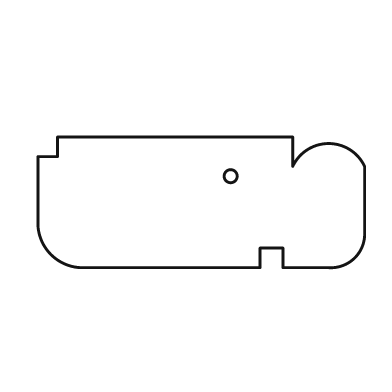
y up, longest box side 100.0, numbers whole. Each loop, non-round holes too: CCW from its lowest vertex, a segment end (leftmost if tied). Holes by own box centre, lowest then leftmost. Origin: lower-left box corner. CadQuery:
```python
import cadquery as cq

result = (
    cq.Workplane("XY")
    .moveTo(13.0, 0.0)
    .lineTo(68.0, 0.0)
    .lineTo(68.0, 6.0)
    .lineTo(75.0, 6.0)
    .lineTo(75.0, 0.0)
    .lineTo(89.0, 0.0)
    .threePointArc((97.0, 3.0), (100.0, 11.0))
    .lineTo(100.0, 31.0)
    .threePointArc((89.0, 38.0), (78.0, 31.0))
    .lineTo(78.0, 40.0)
    .lineTo(6.0, 40.0)
    .lineTo(6.0, 34.0)
    .lineTo(0.0, 34.0)
    .lineTo(0.0, 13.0)
    .threePointArc((4.0, 4.0), (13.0, 0.0))
    .close()
    .moveTo(59.0, 28.0)
    .circle(2.0)
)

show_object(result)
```